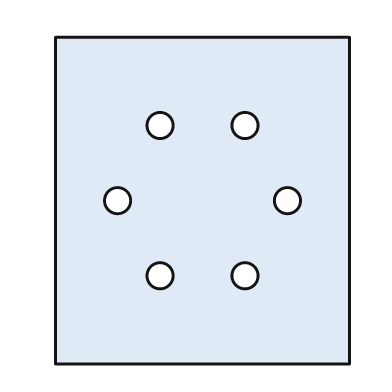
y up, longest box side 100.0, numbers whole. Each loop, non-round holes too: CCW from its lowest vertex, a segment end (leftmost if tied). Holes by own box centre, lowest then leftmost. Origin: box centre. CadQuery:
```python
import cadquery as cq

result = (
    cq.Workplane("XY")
    .moveTo(-45.0, -50.0)
    .lineTo(45.0, -50.0)
    .lineTo(45.0, 50.0)
    .lineTo(-45.0, 50.0)
    .close()
    .moveTo(-13.0, -23.0)
    .circle(4.0)
    .moveTo(13.0, -23.0)
    .circle(4.0)
    .moveTo(-26.0, 0.0)
    .circle(4.0)
    .moveTo(26.0, 0.0)
    .circle(4.0)
    .moveTo(-13.0, 23.0)
    .circle(4.0)
    .moveTo(13.0, 23.0)
    .circle(4.0)
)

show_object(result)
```